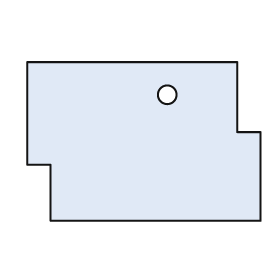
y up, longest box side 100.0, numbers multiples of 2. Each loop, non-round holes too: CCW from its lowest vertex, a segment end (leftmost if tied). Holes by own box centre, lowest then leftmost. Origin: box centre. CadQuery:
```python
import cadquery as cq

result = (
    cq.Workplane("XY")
    .moveTo(-40.0, -34.0)
    .lineTo(50.0, -34.0)
    .lineTo(50.0, 4.0)
    .lineTo(40.0, 4.0)
    .lineTo(40.0, 34.0)
    .lineTo(-50.0, 34.0)
    .lineTo(-50.0, -10.0)
    .lineTo(-40.0, -10.0)
    .close()
    .moveTo(10.0, 20.0)
    .circle(4.0)
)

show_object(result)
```